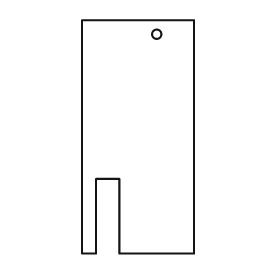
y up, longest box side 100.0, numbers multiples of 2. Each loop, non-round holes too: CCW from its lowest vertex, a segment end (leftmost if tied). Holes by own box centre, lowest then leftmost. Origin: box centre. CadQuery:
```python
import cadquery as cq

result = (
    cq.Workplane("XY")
    .moveTo(-24.0, -50.0)
    .lineTo(-18.0, -50.0)
    .lineTo(-18.0, -18.0)
    .lineTo(-8.0, -18.0)
    .lineTo(-8.0, -50.0)
    .lineTo(24.0, -50.0)
    .lineTo(24.0, 50.0)
    .lineTo(-24.0, 50.0)
    .close()
    .moveTo(8.0, 44.0)
    .circle(2.0)
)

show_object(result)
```